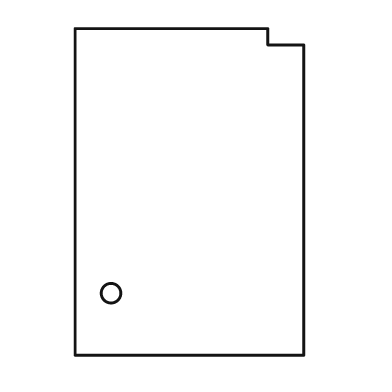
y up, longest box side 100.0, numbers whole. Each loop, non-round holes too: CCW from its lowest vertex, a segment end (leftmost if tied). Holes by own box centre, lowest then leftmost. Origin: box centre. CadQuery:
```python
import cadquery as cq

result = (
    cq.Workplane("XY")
    .moveTo(-35.0, -50.0)
    .lineTo(35.0, -50.0)
    .lineTo(35.0, 45.0)
    .lineTo(24.0, 45.0)
    .lineTo(24.0, 50.0)
    .lineTo(-35.0, 50.0)
    .close()
    .moveTo(-24.0, -31.0)
    .circle(3.0)
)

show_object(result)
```